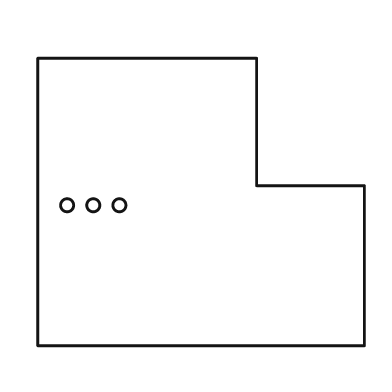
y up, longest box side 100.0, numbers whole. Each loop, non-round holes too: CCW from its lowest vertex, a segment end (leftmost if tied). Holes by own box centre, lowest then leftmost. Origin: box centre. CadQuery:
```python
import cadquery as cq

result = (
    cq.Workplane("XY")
    .moveTo(-50.0, -44.0)
    .lineTo(50.0, -44.0)
    .lineTo(50.0, 5.0)
    .lineTo(17.0, 5.0)
    .lineTo(17.0, 44.0)
    .lineTo(-50.0, 44.0)
    .close()
    .moveTo(-41.0, -1.0)
    .circle(2.0)
    .moveTo(-33.0, -1.0)
    .circle(2.0)
    .moveTo(-25.0, -1.0)
    .circle(2.0)
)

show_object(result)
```